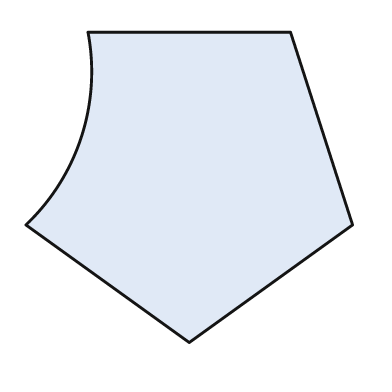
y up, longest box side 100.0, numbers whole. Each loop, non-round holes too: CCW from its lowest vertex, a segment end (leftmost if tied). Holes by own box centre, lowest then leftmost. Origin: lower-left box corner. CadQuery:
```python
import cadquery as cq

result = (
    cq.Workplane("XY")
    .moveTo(50.0, 0.0)
    .lineTo(100.0, 36.0)
    .lineTo(81.0, 95.0)
    .lineTo(19.0, 95.0)
    .threePointArc((17.0, 63.0), (0.0, 36.0))
    .close()
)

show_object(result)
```